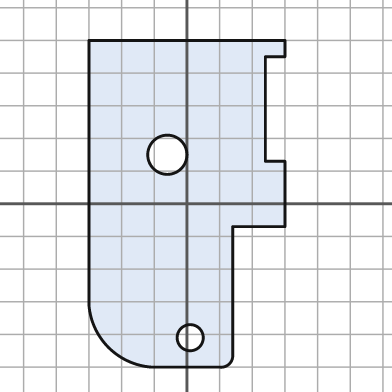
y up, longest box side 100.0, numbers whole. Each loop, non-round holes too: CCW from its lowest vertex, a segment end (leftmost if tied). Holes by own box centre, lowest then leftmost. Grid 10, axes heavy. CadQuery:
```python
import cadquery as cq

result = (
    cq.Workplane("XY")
    .moveTo(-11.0, -50.0)
    .lineTo(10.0, -50.0)
    .threePointArc((13.0, -49.0), (14.0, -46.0))
    .lineTo(14.0, -7.0)
    .lineTo(30.0, -7.0)
    .lineTo(30.0, 13.0)
    .lineTo(24.0, 13.0)
    .lineTo(24.0, 45.0)
    .lineTo(30.0, 45.0)
    .lineTo(30.0, 50.0)
    .lineTo(-30.0, 50.0)
    .lineTo(-30.0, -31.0)
    .threePointArc((-24.0, -44.0), (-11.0, -50.0))
    .close()
    .moveTo(1.0, -41.0)
    .circle(4.0)
    .moveTo(-6.0, 15.0)
    .circle(6.0)
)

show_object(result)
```